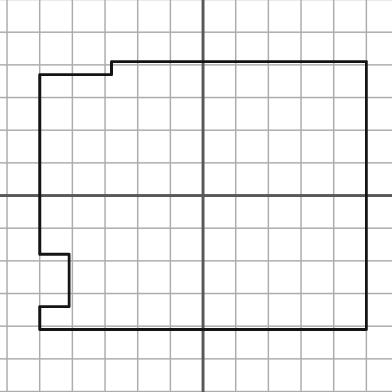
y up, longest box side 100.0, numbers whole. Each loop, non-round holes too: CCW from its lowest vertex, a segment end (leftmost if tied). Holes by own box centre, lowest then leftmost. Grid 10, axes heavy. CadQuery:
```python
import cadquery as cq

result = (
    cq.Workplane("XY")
    .moveTo(-50.0, -41.0)
    .lineTo(50.0, -41.0)
    .lineTo(50.0, 41.0)
    .lineTo(-28.0, 41.0)
    .lineTo(-28.0, 37.0)
    .lineTo(-50.0, 37.0)
    .lineTo(-50.0, -18.0)
    .lineTo(-41.0, -18.0)
    .lineTo(-41.0, -34.0)
    .lineTo(-50.0, -34.0)
    .close()
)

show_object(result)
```